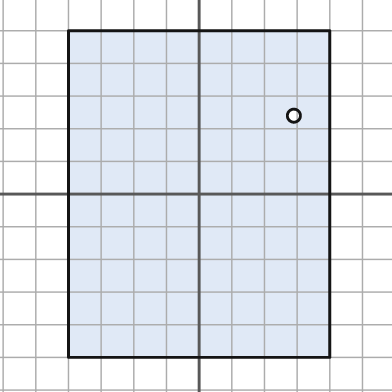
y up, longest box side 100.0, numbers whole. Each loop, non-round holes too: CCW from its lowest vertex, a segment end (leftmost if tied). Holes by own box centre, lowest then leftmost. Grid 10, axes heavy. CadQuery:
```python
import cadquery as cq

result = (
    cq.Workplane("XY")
    .moveTo(-40.0, -50.0)
    .lineTo(40.0, -50.0)
    .lineTo(40.0, 50.0)
    .lineTo(-40.0, 50.0)
    .close()
    .moveTo(29.0, 24.0)
    .circle(2.0)
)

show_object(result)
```